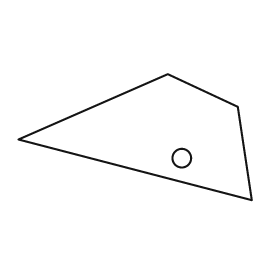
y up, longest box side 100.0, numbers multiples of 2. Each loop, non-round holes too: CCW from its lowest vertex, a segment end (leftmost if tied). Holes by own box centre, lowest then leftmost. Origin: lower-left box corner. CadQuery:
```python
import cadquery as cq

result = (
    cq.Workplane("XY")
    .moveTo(100.0, 0.0)
    .lineTo(94.0, 40.0)
    .lineTo(64.0, 54.0)
    .lineTo(0.0, 26.0)
    .close()
    .moveTo(70.0, 18.0)
    .circle(4.0)
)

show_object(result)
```